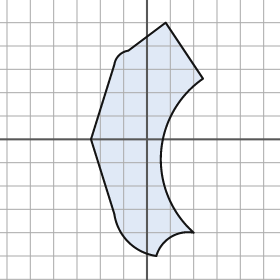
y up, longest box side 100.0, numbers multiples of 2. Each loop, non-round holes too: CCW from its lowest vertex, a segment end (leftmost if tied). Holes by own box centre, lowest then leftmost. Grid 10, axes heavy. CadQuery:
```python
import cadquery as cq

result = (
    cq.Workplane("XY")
    .moveTo(4.0, -50.0)
    .threePointArc((10.0, -42.0), (20.0, -40.0))
    .threePointArc((6.0, -6.0), (24.0, 26.0))
    .lineTo(8.0, 50.0)
    .lineTo(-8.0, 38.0)
    .threePointArc((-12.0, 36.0), (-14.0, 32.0))
    .lineTo(-24.0, 0.0)
    .lineTo(-14.0, -32.0)
    .threePointArc((-8.0, -44.0), (4.0, -50.0))
    .close()
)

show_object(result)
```